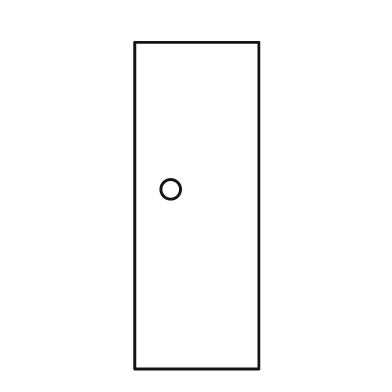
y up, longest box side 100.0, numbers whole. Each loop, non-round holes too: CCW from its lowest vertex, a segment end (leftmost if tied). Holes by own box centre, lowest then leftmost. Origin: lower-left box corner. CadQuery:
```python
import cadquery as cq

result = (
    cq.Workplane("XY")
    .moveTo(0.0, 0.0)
    .lineTo(38.0, 0.0)
    .lineTo(38.0, 100.0)
    .lineTo(0.0, 100.0)
    .close()
    .moveTo(11.0, 55.0)
    .circle(3.0)
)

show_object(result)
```